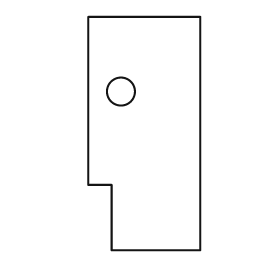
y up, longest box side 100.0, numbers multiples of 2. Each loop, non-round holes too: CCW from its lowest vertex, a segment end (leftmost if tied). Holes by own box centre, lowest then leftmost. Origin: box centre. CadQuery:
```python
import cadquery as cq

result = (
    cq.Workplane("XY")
    .moveTo(-14.0, -50.0)
    .lineTo(24.0, -50.0)
    .lineTo(24.0, 50.0)
    .lineTo(-24.0, 50.0)
    .lineTo(-24.0, -22.0)
    .lineTo(-14.0, -22.0)
    .close()
    .moveTo(-10.0, 18.0)
    .circle(6.0)
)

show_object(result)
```